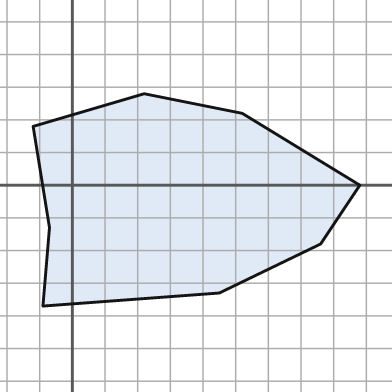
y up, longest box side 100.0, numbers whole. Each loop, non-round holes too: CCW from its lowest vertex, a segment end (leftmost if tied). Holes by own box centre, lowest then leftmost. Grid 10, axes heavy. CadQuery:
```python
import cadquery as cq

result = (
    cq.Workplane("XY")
    .moveTo(-9.0, -37.0)
    .lineTo(45.0, -33.0)
    .lineTo(76.0, -18.0)
    .lineTo(88.0, 0.0)
    .lineTo(52.0, 22.0)
    .lineTo(22.0, 28.0)
    .lineTo(-12.0, 18.0)
    .lineTo(-7.0, -13.0)
    .close()
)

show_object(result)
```